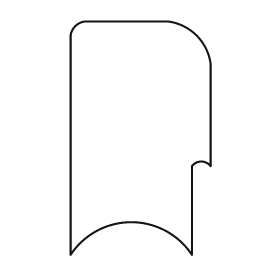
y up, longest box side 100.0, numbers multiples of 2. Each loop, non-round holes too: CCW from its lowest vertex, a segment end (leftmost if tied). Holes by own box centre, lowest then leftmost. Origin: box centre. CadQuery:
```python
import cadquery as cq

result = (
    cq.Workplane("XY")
    .moveTo(-30.0, -50.0)
    .threePointArc((-4.0, -36.0), (22.0, -50.0))
    .lineTo(22.0, -12.0)
    .threePointArc((26.0, -10.0), (30.0, -12.0))
    .lineTo(30.0, 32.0)
    .threePointArc((24.0, 44.0), (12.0, 50.0))
    .lineTo(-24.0, 50.0)
    .threePointArc((-28.0, 48.0), (-30.0, 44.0))
    .close()
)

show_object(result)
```